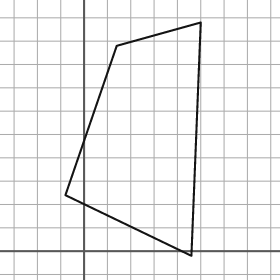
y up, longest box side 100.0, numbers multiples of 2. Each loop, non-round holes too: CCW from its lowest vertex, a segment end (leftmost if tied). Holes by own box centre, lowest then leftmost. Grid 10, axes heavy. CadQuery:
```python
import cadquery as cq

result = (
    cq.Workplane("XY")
    .moveTo(46.0, -2.0)
    .lineTo(50.0, 98.0)
    .lineTo(14.0, 88.0)
    .lineTo(-8.0, 24.0)
    .close()
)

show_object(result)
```